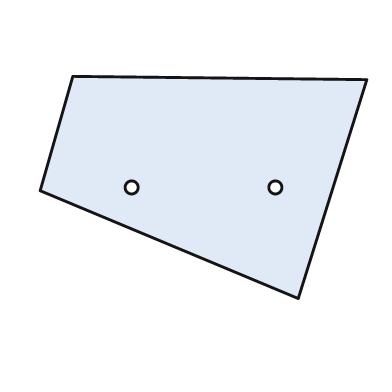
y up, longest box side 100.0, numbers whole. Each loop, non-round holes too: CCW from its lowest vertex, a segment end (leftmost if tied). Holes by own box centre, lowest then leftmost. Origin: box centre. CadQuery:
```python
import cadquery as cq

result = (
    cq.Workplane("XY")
    .moveTo(29.0, -34.0)
    .lineTo(50.0, 33.0)
    .lineTo(-40.0, 34.0)
    .lineTo(-50.0, -1.0)
    .close()
    .moveTo(-22.0, 0.0)
    .circle(2.0)
    .moveTo(22.0, 0.0)
    .circle(2.0)
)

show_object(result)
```